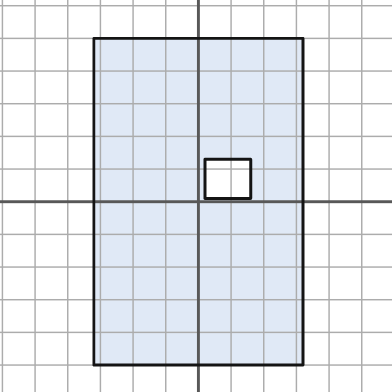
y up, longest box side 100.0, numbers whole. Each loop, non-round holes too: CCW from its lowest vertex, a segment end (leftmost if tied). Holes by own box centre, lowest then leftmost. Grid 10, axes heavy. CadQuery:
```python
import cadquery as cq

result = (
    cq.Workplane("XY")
    .moveTo(-32.0, -50.0)
    .lineTo(32.0, -50.0)
    .lineTo(32.0, 50.0)
    .lineTo(-32.0, 50.0)
    .close()
    .moveTo(2.0, 1.0)
    .lineTo(16.0, 1.0)
    .lineTo(16.0, 13.0)
    .lineTo(2.0, 13.0)
    .close()
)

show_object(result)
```